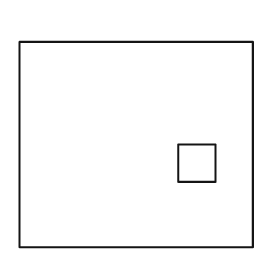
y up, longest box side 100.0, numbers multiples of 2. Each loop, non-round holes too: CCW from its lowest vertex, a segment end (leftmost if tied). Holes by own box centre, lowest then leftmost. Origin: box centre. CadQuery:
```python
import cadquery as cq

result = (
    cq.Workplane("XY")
    .moveTo(-50.0, -44.0)
    .lineTo(50.0, -44.0)
    .lineTo(50.0, 44.0)
    .lineTo(-50.0, 44.0)
    .close()
    .moveTo(18.0, -16.0)
    .lineTo(34.0, -16.0)
    .lineTo(34.0, 0.0)
    .lineTo(18.0, 0.0)
    .close()
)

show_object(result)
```